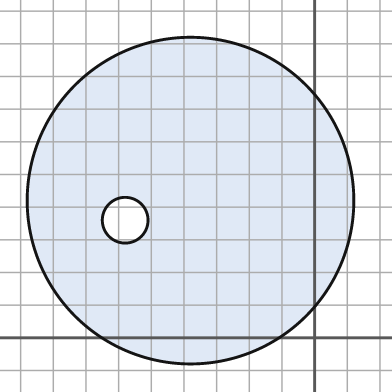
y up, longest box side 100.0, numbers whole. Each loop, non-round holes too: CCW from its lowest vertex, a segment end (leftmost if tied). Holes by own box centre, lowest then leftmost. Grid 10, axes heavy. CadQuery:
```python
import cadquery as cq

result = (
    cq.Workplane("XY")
    .moveTo(-38.0, 42.0)
    .circle(50.0)
    .moveTo(-58.0, 36.0)
    .circle(7.0)
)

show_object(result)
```